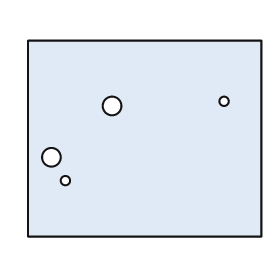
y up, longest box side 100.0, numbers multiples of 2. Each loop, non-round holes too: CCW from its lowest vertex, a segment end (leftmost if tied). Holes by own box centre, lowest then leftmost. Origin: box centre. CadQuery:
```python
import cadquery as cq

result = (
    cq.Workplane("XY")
    .moveTo(-50.0, -42.0)
    .lineTo(50.0, -42.0)
    .lineTo(50.0, 42.0)
    .lineTo(-50.0, 42.0)
    .close()
    .moveTo(-34.0, -18.0)
    .circle(2.0)
    .moveTo(-40.0, -8.0)
    .circle(4.0)
    .moveTo(-14.0, 14.0)
    .circle(4.0)
    .moveTo(34.0, 16.0)
    .circle(2.0)
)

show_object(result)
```